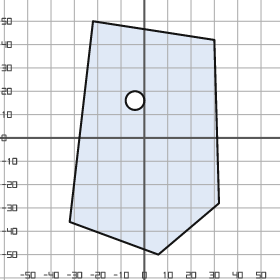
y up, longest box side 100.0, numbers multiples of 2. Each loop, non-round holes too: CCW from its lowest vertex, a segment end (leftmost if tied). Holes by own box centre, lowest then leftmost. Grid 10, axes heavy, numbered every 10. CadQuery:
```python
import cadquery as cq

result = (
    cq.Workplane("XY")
    .moveTo(6.0, -50.0)
    .lineTo(32.0, -28.0)
    .lineTo(30.0, 42.0)
    .lineTo(-22.0, 50.0)
    .lineTo(-32.0, -36.0)
    .close()
    .moveTo(-4.0, 16.0)
    .circle(4.0)
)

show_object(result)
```